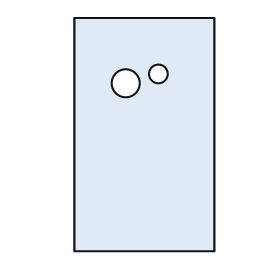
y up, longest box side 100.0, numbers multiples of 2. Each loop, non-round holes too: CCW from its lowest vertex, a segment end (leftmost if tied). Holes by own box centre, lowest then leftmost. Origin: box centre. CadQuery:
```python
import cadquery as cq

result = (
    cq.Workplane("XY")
    .moveTo(-30.0, -50.0)
    .lineTo(30.0, -50.0)
    .lineTo(30.0, 50.0)
    .lineTo(-30.0, 50.0)
    .close()
    .moveTo(-8.0, 22.0)
    .circle(6.0)
    .moveTo(6.0, 26.0)
    .circle(4.0)
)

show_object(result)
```